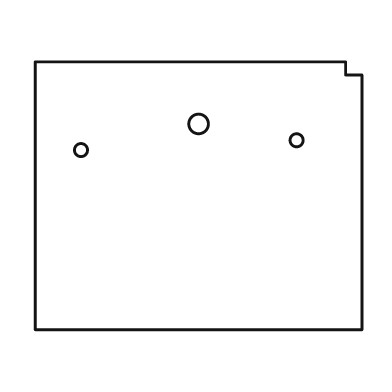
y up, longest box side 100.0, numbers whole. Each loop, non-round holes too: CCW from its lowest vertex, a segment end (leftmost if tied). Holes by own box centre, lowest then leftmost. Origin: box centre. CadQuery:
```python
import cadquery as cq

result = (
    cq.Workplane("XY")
    .moveTo(-50.0, -41.0)
    .lineTo(50.0, -41.0)
    .lineTo(50.0, 37.0)
    .lineTo(45.0, 37.0)
    .lineTo(45.0, 41.0)
    .lineTo(-50.0, 41.0)
    .close()
    .moveTo(-36.0, 14.0)
    .circle(2.0)
    .moveTo(30.0, 17.0)
    .circle(2.0)
    .moveTo(0.0, 22.0)
    .circle(3.0)
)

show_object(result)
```